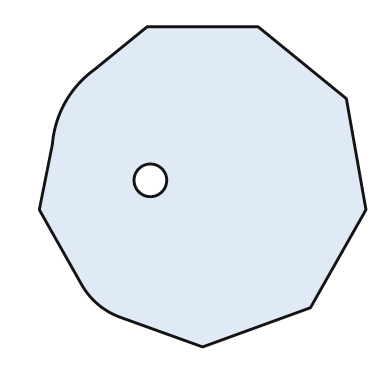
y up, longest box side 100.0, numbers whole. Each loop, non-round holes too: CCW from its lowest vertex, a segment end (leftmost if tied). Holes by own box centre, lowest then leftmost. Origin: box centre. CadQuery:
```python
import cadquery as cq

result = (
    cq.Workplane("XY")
    .moveTo(0.0, -49.0)
    .lineTo(33.0, -37.0)
    .lineTo(50.0, -7.0)
    .lineTo(44.0, 27.0)
    .lineTo(17.0, 49.0)
    .lineTo(-17.0, 49.0)
    .lineTo(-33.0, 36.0)
    .threePointArc((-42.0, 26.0), (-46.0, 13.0))
    .lineTo(-50.0, -7.0)
    .lineTo(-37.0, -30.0)
    .threePointArc((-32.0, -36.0), (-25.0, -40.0))
    .close()
    .moveTo(-16.0, 2.0)
    .circle(5.0)
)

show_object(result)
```